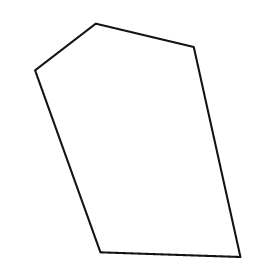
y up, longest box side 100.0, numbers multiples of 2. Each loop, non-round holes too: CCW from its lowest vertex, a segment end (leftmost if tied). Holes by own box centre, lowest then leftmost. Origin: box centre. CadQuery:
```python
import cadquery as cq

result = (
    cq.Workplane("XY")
    .moveTo(44.0, -50.0)
    .lineTo(24.0, 40.0)
    .lineTo(-18.0, 50.0)
    .lineTo(-44.0, 30.0)
    .lineTo(-16.0, -48.0)
    .close()
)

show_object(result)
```